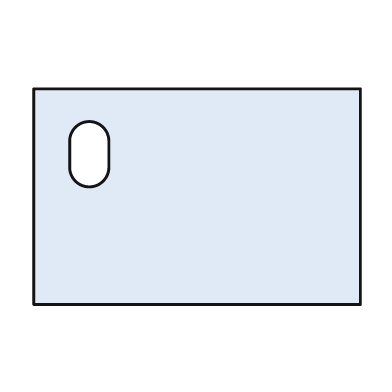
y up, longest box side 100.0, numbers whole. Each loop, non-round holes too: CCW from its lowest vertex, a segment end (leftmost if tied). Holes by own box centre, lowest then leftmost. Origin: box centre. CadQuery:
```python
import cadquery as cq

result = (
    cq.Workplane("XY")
    .moveTo(-50.0, -33.0)
    .lineTo(50.0, -33.0)
    .lineTo(50.0, 33.0)
    .lineTo(-50.0, 33.0)
    .close()
    .moveTo(-39.0, 9.0)
    .threePointArc((-33.0, 3.0), (-27.0, 9.0))
    .lineTo(-27.0, 17.0)
    .threePointArc((-33.0, 23.0), (-39.0, 17.0))
    .close()
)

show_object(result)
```